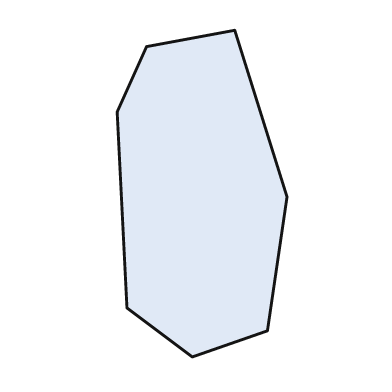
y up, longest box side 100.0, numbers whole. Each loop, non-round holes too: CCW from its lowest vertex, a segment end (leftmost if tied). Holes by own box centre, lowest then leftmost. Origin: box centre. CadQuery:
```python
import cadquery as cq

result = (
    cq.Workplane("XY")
    .moveTo(-3.0, -50.0)
    .lineTo(20.0, -42.0)
    .lineTo(26.0, -1.0)
    .lineTo(10.0, 50.0)
    .lineTo(-17.0, 45.0)
    .lineTo(-26.0, 25.0)
    .lineTo(-23.0, -35.0)
    .close()
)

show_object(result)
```